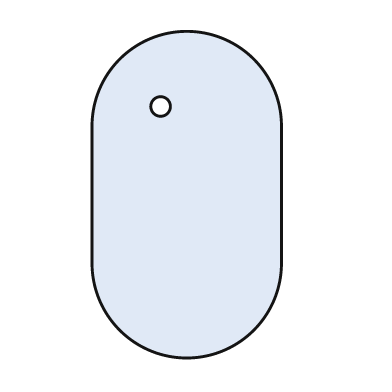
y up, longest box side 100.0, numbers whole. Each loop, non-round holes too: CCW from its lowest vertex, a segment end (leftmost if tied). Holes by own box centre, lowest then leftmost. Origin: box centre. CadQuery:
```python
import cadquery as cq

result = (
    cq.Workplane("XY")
    .moveTo(-29.0, -21.0)
    .threePointArc((0.0, -50.0), (29.0, -21.0))
    .lineTo(29.0, 21.0)
    .threePointArc((0.0, 50.0), (-29.0, 21.0))
    .close()
    .moveTo(-8.0, 27.0)
    .circle(3.0)
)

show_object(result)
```